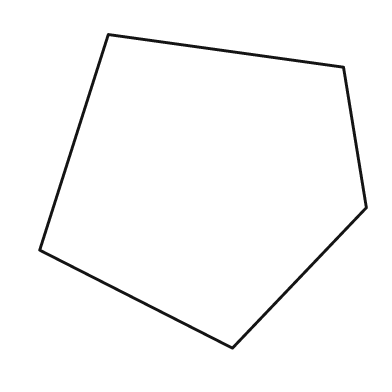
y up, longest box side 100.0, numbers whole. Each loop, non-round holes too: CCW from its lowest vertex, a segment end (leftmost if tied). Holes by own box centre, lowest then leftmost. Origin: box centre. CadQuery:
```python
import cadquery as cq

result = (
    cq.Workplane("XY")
    .moveTo(9.0, -48.0)
    .lineTo(50.0, -5.0)
    .lineTo(43.0, 38.0)
    .lineTo(-29.0, 48.0)
    .lineTo(-50.0, -18.0)
    .close()
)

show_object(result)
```